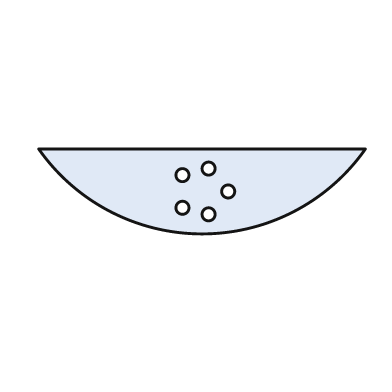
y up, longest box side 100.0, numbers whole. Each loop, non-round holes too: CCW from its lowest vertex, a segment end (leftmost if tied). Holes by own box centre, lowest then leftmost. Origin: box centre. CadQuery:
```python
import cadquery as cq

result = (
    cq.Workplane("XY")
    .moveTo(-50.0, 13.0)
    .threePointArc((0.0, -13.0), (50.0, 13.0))
    .close()
    .moveTo(2.0, -7.0)
    .circle(2.0)
    .moveTo(-6.0, -5.0)
    .circle(2.0)
    .moveTo(8.0, 0.0)
    .circle(2.0)
    .moveTo(-6.0, 5.0)
    .circle(2.0)
    .moveTo(2.0, 7.0)
    .circle(2.0)
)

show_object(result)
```